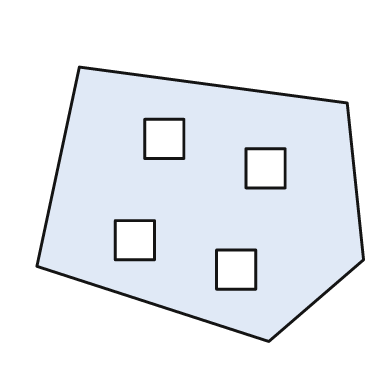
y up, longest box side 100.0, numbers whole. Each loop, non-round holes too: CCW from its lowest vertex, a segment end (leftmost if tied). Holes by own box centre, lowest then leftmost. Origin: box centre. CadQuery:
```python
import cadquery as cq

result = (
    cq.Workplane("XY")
    .moveTo(21.0, -42.0)
    .lineTo(50.0, -17.0)
    .lineTo(45.0, 31.0)
    .lineTo(-37.0, 42.0)
    .lineTo(-50.0, -19.0)
    .close()
    .moveTo(5.0, -26.0)
    .lineTo(17.0, -26.0)
    .lineTo(17.0, -14.0)
    .lineTo(5.0, -14.0)
    .close()
    .moveTo(-26.0, -17.0)
    .lineTo(-14.0, -17.0)
    .lineTo(-14.0, -5.0)
    .lineTo(-26.0, -5.0)
    .close()
    .moveTo(14.0, 5.0)
    .lineTo(26.0, 5.0)
    .lineTo(26.0, 17.0)
    .lineTo(14.0, 17.0)
    .close()
    .moveTo(-17.0, 14.0)
    .lineTo(-5.0, 14.0)
    .lineTo(-5.0, 26.0)
    .lineTo(-17.0, 26.0)
    .close()
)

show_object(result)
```